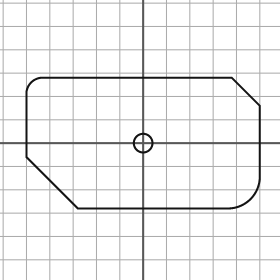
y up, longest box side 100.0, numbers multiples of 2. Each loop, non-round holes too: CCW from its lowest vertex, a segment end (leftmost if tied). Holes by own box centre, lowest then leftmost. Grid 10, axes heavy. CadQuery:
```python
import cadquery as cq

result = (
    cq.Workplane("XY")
    .moveTo(-28.0, -28.0)
    .lineTo(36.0, -28.0)
    .threePointArc((46.0, -24.0), (50.0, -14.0))
    .lineTo(50.0, 16.0)
    .lineTo(38.0, 28.0)
    .lineTo(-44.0, 28.0)
    .threePointArc((-48.0, 26.0), (-50.0, 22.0))
    .lineTo(-50.0, -6.0)
    .close()
    .moveTo(0.0, 0.0)
    .circle(4.0)
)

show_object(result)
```